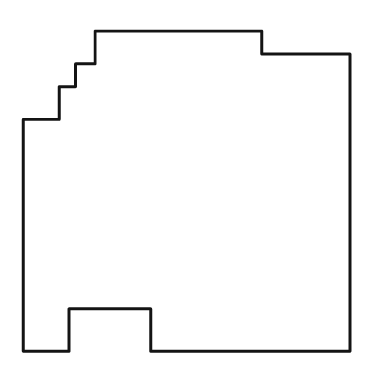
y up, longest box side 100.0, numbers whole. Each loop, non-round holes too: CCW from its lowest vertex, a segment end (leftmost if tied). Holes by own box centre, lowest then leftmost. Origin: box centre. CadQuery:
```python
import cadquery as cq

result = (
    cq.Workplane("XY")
    .moveTo(-50.0, -49.0)
    .lineTo(-36.0, -49.0)
    .lineTo(-36.0, -36.0)
    .lineTo(-11.0, -36.0)
    .lineTo(-11.0, -49.0)
    .lineTo(50.0, -49.0)
    .lineTo(50.0, 42.0)
    .lineTo(23.0, 42.0)
    .lineTo(23.0, 49.0)
    .lineTo(-28.0, 49.0)
    .lineTo(-28.0, 39.0)
    .lineTo(-34.0, 39.0)
    .lineTo(-34.0, 32.0)
    .lineTo(-39.0, 32.0)
    .lineTo(-39.0, 22.0)
    .lineTo(-50.0, 22.0)
    .close()
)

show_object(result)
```